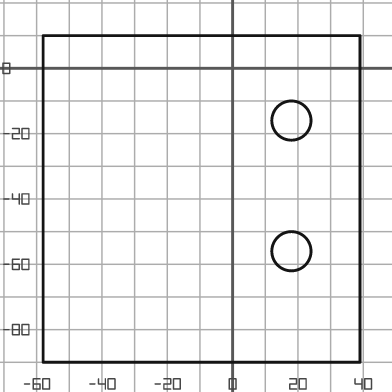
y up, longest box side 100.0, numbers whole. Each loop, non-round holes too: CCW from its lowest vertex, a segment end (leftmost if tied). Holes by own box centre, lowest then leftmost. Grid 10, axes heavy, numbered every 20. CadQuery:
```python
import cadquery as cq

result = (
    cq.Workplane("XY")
    .moveTo(-58.0, -90.0)
    .lineTo(39.0, -90.0)
    .lineTo(39.0, 10.0)
    .lineTo(-58.0, 10.0)
    .close()
    .moveTo(18.0, -56.0)
    .circle(6.0)
    .moveTo(18.0, -16.0)
    .circle(6.0)
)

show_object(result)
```